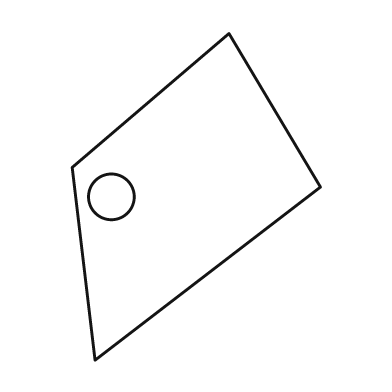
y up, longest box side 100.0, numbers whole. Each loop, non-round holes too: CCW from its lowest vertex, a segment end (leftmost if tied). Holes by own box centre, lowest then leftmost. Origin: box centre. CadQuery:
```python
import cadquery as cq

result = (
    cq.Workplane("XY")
    .moveTo(-31.0, -50.0)
    .lineTo(38.0, 3.0)
    .lineTo(10.0, 50.0)
    .lineTo(-38.0, 9.0)
    .close()
    .moveTo(-26.0, 0.0)
    .circle(7.0)
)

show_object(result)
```